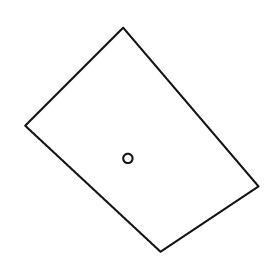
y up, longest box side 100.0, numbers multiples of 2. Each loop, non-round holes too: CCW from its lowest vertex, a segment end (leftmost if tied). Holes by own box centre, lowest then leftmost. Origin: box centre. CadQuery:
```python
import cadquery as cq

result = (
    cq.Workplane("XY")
    .moveTo(8.0, -48.0)
    .lineTo(50.0, -20.0)
    .lineTo(-8.0, 48.0)
    .lineTo(-50.0, 6.0)
    .close()
    .moveTo(-6.0, -8.0)
    .circle(2.0)
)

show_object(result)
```